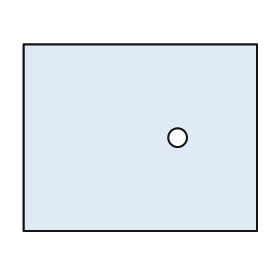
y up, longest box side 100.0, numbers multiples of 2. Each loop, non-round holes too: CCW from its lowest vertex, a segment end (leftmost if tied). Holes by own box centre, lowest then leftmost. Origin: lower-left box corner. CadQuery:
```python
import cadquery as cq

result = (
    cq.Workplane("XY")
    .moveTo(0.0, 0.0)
    .lineTo(100.0, 0.0)
    .lineTo(100.0, 80.0)
    .lineTo(0.0, 80.0)
    .close()
    .moveTo(66.0, 40.0)
    .circle(4.0)
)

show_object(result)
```